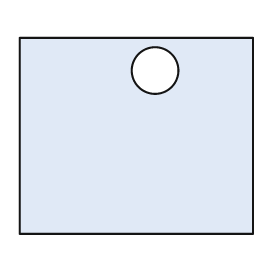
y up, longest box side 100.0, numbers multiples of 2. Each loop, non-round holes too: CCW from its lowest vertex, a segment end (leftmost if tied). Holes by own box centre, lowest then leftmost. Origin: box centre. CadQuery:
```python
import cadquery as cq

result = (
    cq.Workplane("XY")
    .moveTo(-50.0, -42.0)
    .lineTo(50.0, -42.0)
    .lineTo(50.0, 42.0)
    .lineTo(-50.0, 42.0)
    .close()
    .moveTo(8.0, 28.0)
    .circle(10.0)
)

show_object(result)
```